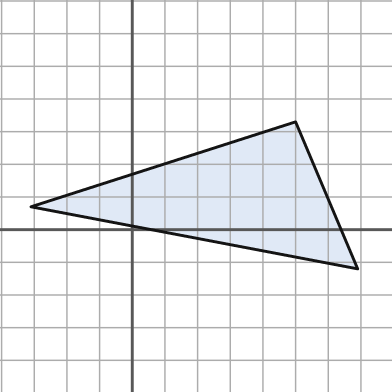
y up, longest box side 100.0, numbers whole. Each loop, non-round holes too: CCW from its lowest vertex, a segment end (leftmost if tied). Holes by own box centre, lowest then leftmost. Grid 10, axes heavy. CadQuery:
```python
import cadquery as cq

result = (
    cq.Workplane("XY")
    .moveTo(69.0, -12.0)
    .lineTo(50.0, 33.0)
    .lineTo(-31.0, 7.0)
    .close()
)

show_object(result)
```